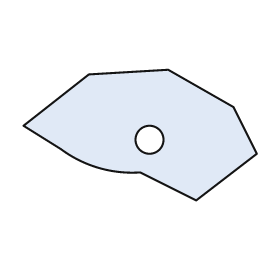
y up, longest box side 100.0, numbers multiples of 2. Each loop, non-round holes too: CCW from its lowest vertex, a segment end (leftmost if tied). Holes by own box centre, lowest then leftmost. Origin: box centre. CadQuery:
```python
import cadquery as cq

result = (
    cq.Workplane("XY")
    .moveTo(24.0, -28.0)
    .lineTo(50.0, -8.0)
    .lineTo(40.0, 12.0)
    .lineTo(12.0, 28.0)
    .lineTo(-22.0, 26.0)
    .lineTo(-50.0, 4.0)
    .lineTo(-34.0, -6.0)
    .threePointArc((-18.0, -14.0), (0.0, -16.0))
    .close()
    .moveTo(4.0, -2.0)
    .circle(6.0)
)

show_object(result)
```